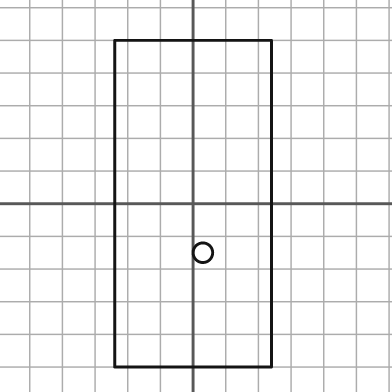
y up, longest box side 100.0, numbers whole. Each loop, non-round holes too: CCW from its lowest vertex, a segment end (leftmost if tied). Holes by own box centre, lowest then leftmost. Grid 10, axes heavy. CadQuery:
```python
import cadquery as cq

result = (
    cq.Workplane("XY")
    .moveTo(-24.0, -50.0)
    .lineTo(24.0, -50.0)
    .lineTo(24.0, 50.0)
    .lineTo(-24.0, 50.0)
    .close()
    .moveTo(3.0, -15.0)
    .circle(3.0)
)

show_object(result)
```